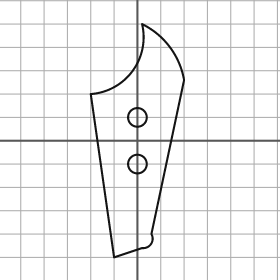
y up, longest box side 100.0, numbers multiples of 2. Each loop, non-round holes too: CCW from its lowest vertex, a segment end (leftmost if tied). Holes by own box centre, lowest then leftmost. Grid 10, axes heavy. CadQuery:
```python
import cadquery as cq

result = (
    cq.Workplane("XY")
    .moveTo(-10.0, -50.0)
    .lineTo(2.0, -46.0)
    .threePointArc((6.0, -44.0), (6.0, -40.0))
    .lineTo(20.0, 26.0)
    .threePointArc((14.0, 40.0), (2.0, 50.0))
    .threePointArc((-2.0, 30.0), (-20.0, 20.0))
    .close()
    .moveTo(0.0, -10.0)
    .circle(4.0)
    .moveTo(0.0, 10.0)
    .circle(4.0)
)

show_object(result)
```